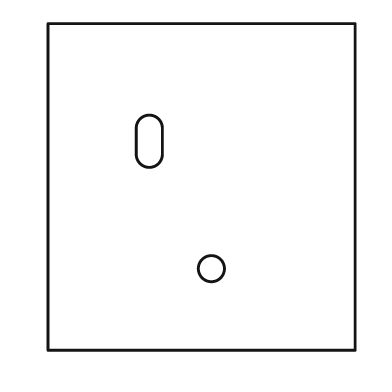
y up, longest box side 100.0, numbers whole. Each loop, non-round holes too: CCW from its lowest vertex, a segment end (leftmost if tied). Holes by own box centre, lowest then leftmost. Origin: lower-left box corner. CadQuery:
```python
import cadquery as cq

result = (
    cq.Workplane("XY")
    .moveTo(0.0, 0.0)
    .lineTo(94.0, 0.0)
    .lineTo(94.0, 100.0)
    .lineTo(0.0, 100.0)
    .close()
    .moveTo(50.0, 25.0)
    .circle(4.0)
    .moveTo(27.0, 60.0)
    .threePointArc((31.0, 56.0), (35.0, 60.0))
    .lineTo(35.0, 68.0)
    .threePointArc((31.0, 72.0), (27.0, 68.0))
    .close()
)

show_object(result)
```